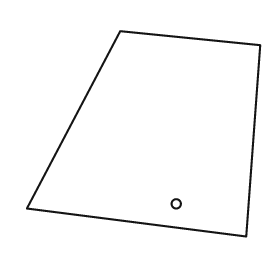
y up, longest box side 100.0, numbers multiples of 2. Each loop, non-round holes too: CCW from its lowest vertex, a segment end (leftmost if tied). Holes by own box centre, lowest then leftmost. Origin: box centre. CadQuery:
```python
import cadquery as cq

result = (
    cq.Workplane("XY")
    .moveTo(44.0, -44.0)
    .lineTo(50.0, 38.0)
    .lineTo(-10.0, 44.0)
    .lineTo(-50.0, -32.0)
    .close()
    .moveTo(14.0, -30.0)
    .circle(2.0)
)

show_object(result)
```